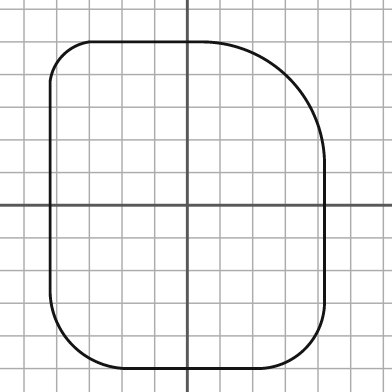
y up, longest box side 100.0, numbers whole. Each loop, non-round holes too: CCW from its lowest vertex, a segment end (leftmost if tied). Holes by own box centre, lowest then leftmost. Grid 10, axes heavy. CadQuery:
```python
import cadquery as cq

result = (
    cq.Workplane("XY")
    .moveTo(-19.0, -50.0)
    .lineTo(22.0, -50.0)
    .threePointArc((36.0, -44.0), (42.0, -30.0))
    .lineTo(42.0, 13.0)
    .threePointArc((31.0, 39.0), (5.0, 50.0))
    .lineTo(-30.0, 50.0)
    .threePointArc((-38.0, 46.0), (-42.0, 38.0))
    .lineTo(-42.0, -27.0)
    .threePointArc((-35.0, -43.0), (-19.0, -50.0))
    .close()
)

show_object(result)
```